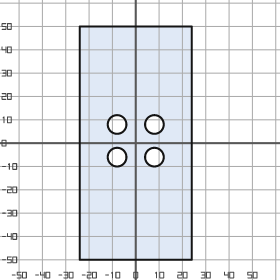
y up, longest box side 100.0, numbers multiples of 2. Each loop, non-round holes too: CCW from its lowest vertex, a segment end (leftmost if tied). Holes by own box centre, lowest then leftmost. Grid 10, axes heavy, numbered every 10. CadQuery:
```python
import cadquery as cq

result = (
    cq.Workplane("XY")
    .moveTo(-24.0, -50.0)
    .lineTo(24.0, -50.0)
    .lineTo(24.0, 50.0)
    .lineTo(-24.0, 50.0)
    .close()
    .moveTo(-8.0, -6.0)
    .circle(4.0)
    .moveTo(8.0, -6.0)
    .circle(4.0)
    .moveTo(-8.0, 8.0)
    .circle(4.0)
    .moveTo(8.0, 8.0)
    .circle(4.0)
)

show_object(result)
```